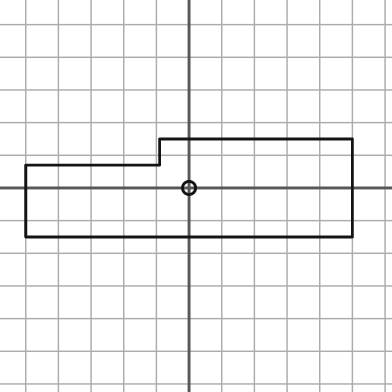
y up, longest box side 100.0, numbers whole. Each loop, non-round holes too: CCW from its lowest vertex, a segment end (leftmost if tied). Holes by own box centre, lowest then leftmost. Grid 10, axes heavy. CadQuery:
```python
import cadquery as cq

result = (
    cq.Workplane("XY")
    .moveTo(-50.0, -15.0)
    .lineTo(50.0, -15.0)
    .lineTo(50.0, 15.0)
    .lineTo(-9.0, 15.0)
    .lineTo(-9.0, 7.0)
    .lineTo(-50.0, 7.0)
    .close()
    .moveTo(0.0, 0.0)
    .circle(2.0)
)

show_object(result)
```